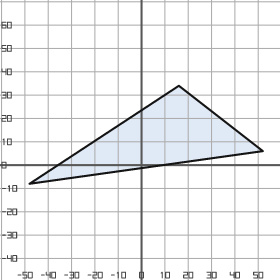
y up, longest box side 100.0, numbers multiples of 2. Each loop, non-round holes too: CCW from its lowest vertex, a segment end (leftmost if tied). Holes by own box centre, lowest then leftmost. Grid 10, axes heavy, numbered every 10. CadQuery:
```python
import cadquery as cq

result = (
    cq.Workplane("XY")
    .moveTo(-48.0, -8.0)
    .lineTo(52.0, 6.0)
    .lineTo(16.0, 34.0)
    .close()
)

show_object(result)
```